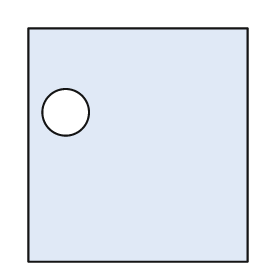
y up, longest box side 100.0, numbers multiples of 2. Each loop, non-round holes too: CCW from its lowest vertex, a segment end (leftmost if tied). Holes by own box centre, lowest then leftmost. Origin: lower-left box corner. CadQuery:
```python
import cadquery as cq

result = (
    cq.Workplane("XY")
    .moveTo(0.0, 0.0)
    .lineTo(94.0, 0.0)
    .lineTo(94.0, 100.0)
    .lineTo(0.0, 100.0)
    .close()
    .moveTo(16.0, 64.0)
    .circle(10.0)
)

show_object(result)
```